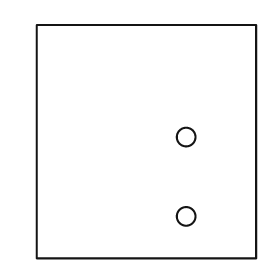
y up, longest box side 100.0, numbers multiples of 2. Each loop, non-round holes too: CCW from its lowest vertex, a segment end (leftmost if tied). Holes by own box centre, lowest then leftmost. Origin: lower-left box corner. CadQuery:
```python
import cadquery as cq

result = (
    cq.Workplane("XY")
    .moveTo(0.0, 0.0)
    .lineTo(94.0, 0.0)
    .lineTo(94.0, 100.0)
    .lineTo(0.0, 100.0)
    .close()
    .moveTo(64.0, 18.0)
    .circle(4.0)
    .moveTo(64.0, 52.0)
    .circle(4.0)
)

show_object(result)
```